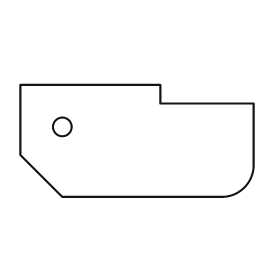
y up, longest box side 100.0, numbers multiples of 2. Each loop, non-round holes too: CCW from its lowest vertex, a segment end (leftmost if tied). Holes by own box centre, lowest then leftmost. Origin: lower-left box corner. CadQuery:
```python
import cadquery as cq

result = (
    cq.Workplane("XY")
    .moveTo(18.0, 0.0)
    .lineTo(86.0, 0.0)
    .threePointArc((96.0, 4.0), (100.0, 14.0))
    .lineTo(100.0, 40.0)
    .lineTo(60.0, 40.0)
    .lineTo(60.0, 48.0)
    .lineTo(0.0, 48.0)
    .lineTo(0.0, 18.0)
    .close()
    .moveTo(18.0, 30.0)
    .circle(4.0)
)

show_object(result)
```